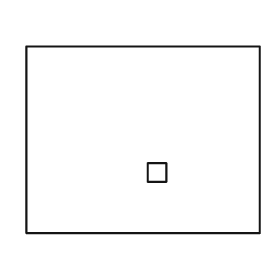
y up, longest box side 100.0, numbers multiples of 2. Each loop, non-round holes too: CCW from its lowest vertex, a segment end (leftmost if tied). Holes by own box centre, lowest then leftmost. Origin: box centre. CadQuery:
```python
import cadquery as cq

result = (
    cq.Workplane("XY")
    .moveTo(-50.0, -40.0)
    .lineTo(50.0, -40.0)
    .lineTo(50.0, 40.0)
    .lineTo(-50.0, 40.0)
    .close()
    .moveTo(2.0, -18.0)
    .lineTo(10.0, -18.0)
    .lineTo(10.0, -10.0)
    .lineTo(2.0, -10.0)
    .close()
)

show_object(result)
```